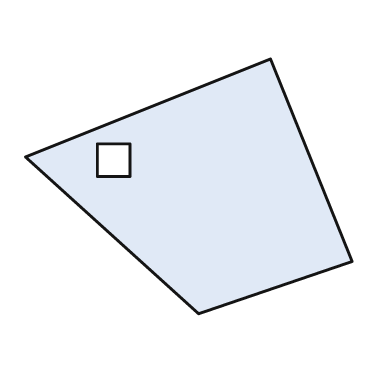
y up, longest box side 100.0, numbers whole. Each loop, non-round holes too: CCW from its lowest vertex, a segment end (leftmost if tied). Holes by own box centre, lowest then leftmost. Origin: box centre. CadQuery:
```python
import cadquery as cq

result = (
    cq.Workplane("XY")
    .moveTo(3.0, -39.0)
    .lineTo(50.0, -23.0)
    .lineTo(25.0, 39.0)
    .lineTo(-50.0, 9.0)
    .close()
    .moveTo(-28.0, 3.0)
    .lineTo(-18.0, 3.0)
    .lineTo(-18.0, 13.0)
    .lineTo(-28.0, 13.0)
    .close()
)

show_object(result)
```